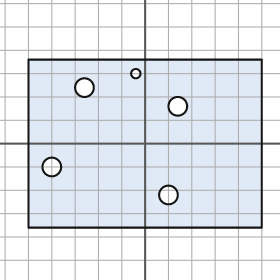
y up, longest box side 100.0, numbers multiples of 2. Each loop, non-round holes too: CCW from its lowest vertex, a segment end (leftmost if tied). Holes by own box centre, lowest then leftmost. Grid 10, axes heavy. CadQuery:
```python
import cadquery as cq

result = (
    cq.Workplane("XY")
    .moveTo(-50.0, -36.0)
    .lineTo(50.0, -36.0)
    .lineTo(50.0, 36.0)
    .lineTo(-50.0, 36.0)
    .close()
    .moveTo(10.0, -22.0)
    .circle(4.0)
    .moveTo(-40.0, -10.0)
    .circle(4.0)
    .moveTo(14.0, 16.0)
    .circle(4.0)
    .moveTo(-26.0, 24.0)
    .circle(4.0)
    .moveTo(-4.0, 30.0)
    .circle(2.0)
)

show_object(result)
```